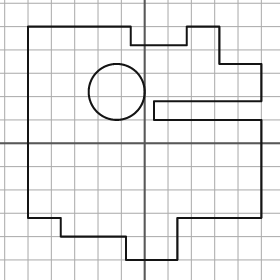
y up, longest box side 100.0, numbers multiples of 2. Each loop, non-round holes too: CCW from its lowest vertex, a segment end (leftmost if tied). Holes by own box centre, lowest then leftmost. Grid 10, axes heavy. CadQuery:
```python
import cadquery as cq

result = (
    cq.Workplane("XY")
    .moveTo(-8.0, -50.0)
    .lineTo(14.0, -50.0)
    .lineTo(14.0, -32.0)
    .lineTo(50.0, -32.0)
    .lineTo(50.0, 10.0)
    .lineTo(4.0, 10.0)
    .lineTo(4.0, 18.0)
    .lineTo(50.0, 18.0)
    .lineTo(50.0, 34.0)
    .lineTo(32.0, 34.0)
    .lineTo(32.0, 50.0)
    .lineTo(18.0, 50.0)
    .lineTo(18.0, 42.0)
    .lineTo(-6.0, 42.0)
    .lineTo(-6.0, 50.0)
    .lineTo(-50.0, 50.0)
    .lineTo(-50.0, -32.0)
    .lineTo(-36.0, -32.0)
    .lineTo(-36.0, -40.0)
    .lineTo(-8.0, -40.0)
    .close()
    .moveTo(-12.0, 22.0)
    .circle(12.0)
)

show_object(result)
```